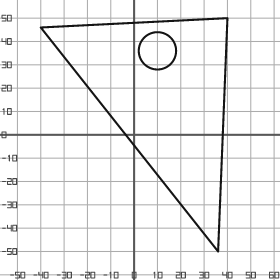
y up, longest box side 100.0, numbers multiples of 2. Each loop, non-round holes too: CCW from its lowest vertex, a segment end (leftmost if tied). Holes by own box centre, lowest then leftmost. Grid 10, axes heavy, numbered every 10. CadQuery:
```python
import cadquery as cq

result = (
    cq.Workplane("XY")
    .moveTo(36.0, -50.0)
    .lineTo(40.0, 50.0)
    .lineTo(-40.0, 46.0)
    .close()
    .moveTo(10.0, 36.0)
    .circle(8.0)
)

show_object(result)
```